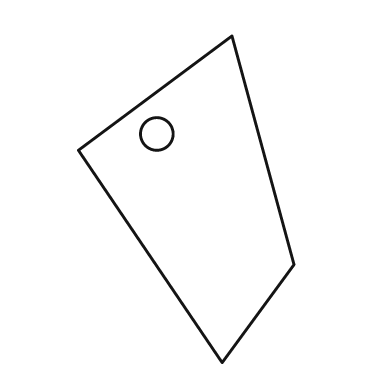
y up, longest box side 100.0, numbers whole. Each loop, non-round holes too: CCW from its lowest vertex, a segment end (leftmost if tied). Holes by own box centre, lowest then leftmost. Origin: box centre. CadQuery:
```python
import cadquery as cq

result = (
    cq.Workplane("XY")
    .moveTo(11.0, -50.0)
    .lineTo(33.0, -20.0)
    .lineTo(14.0, 50.0)
    .lineTo(-33.0, 15.0)
    .close()
    .moveTo(-9.0, 20.0)
    .circle(5.0)
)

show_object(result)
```